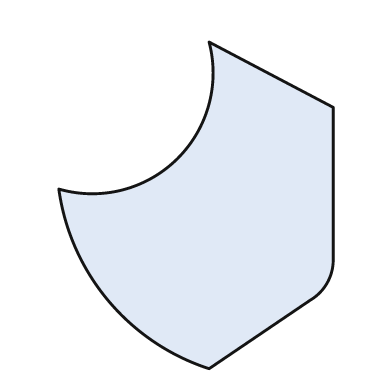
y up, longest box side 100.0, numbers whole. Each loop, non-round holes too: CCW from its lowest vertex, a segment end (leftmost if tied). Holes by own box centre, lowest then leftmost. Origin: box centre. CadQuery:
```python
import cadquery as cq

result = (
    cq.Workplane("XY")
    .moveTo(4.0, -50.0)
    .lineTo(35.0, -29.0)
    .threePointArc((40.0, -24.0), (42.0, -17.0))
    .lineTo(42.0, 30.0)
    .lineTo(4.0, 50.0)
    .threePointArc((-6.0, 14.0), (-42.0, 5.0))
    .threePointArc((-27.0, -29.0), (4.0, -50.0))
    .close()
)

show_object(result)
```